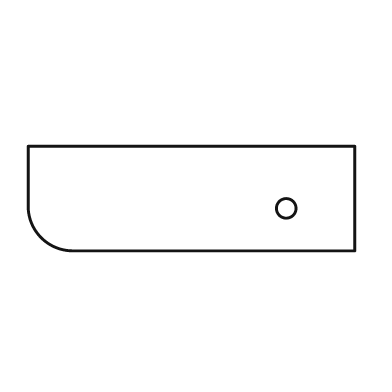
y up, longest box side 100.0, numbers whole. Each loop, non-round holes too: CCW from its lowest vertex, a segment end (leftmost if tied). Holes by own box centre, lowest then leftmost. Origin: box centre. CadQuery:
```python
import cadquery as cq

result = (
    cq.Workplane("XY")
    .moveTo(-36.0, -16.0)
    .lineTo(50.0, -16.0)
    .lineTo(50.0, 16.0)
    .lineTo(-50.0, 16.0)
    .lineTo(-50.0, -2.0)
    .threePointArc((-46.0, -12.0), (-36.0, -16.0))
    .close()
    .moveTo(29.0, -3.0)
    .circle(3.0)
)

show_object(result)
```